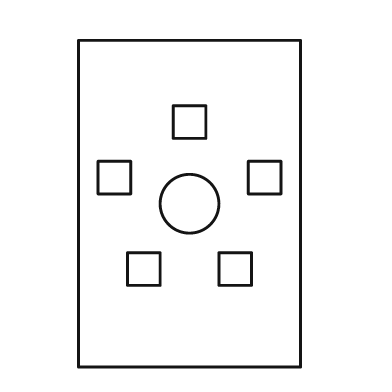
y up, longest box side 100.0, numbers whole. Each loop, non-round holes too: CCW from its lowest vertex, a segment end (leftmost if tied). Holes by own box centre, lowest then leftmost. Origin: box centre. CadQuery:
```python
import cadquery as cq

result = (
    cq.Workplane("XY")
    .moveTo(-34.0, -50.0)
    .lineTo(34.0, -50.0)
    .lineTo(34.0, 50.0)
    .lineTo(-34.0, 50.0)
    .close()
    .moveTo(-19.0, -25.0)
    .lineTo(-9.0, -25.0)
    .lineTo(-9.0, -15.0)
    .lineTo(-19.0, -15.0)
    .close()
    .moveTo(9.0, -25.0)
    .lineTo(19.0, -25.0)
    .lineTo(19.0, -15.0)
    .lineTo(9.0, -15.0)
    .close()
    .moveTo(0.0, 0.0)
    .circle(9.0)
    .moveTo(-28.0, 3.0)
    .lineTo(-18.0, 3.0)
    .lineTo(-18.0, 13.0)
    .lineTo(-28.0, 13.0)
    .close()
    .moveTo(18.0, 3.0)
    .lineTo(28.0, 3.0)
    .lineTo(28.0, 13.0)
    .lineTo(18.0, 13.0)
    .close()
    .moveTo(-5.0, 20.0)
    .lineTo(5.0, 20.0)
    .lineTo(5.0, 30.0)
    .lineTo(-5.0, 30.0)
    .close()
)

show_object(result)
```